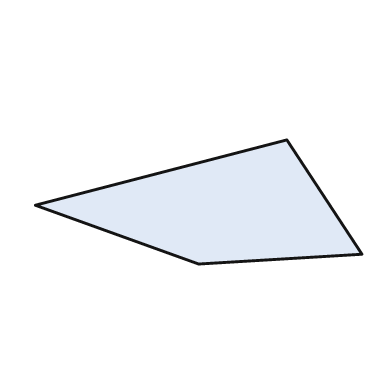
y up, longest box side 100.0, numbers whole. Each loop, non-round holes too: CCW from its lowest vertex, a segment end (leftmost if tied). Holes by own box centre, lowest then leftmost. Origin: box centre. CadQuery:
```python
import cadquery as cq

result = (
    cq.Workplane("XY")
    .moveTo(0.0, -19.0)
    .lineTo(50.0, -16.0)
    .lineTo(27.0, 19.0)
    .lineTo(-50.0, -1.0)
    .close()
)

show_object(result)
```